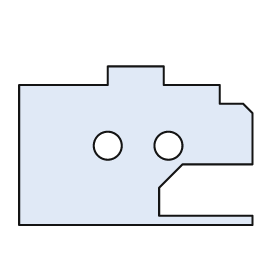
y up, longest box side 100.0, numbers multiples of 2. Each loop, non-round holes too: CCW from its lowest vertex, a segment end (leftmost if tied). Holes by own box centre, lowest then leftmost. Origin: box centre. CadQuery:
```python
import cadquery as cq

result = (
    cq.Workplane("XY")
    .moveTo(-50.0, -34.0)
    .lineTo(50.0, -34.0)
    .lineTo(50.0, -30.0)
    .lineTo(10.0, -30.0)
    .lineTo(10.0, -18.0)
    .lineTo(20.0, -8.0)
    .lineTo(50.0, -8.0)
    .lineTo(50.0, 14.0)
    .lineTo(46.0, 18.0)
    .lineTo(36.0, 18.0)
    .lineTo(36.0, 26.0)
    .lineTo(12.0, 26.0)
    .lineTo(12.0, 34.0)
    .lineTo(-12.0, 34.0)
    .lineTo(-12.0, 26.0)
    .lineTo(-50.0, 26.0)
    .close()
    .moveTo(-12.0, 0.0)
    .circle(6.0)
    .moveTo(14.0, 0.0)
    .circle(6.0)
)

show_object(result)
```